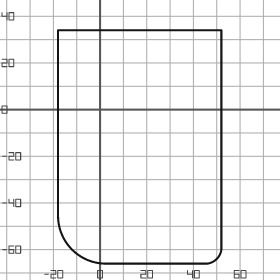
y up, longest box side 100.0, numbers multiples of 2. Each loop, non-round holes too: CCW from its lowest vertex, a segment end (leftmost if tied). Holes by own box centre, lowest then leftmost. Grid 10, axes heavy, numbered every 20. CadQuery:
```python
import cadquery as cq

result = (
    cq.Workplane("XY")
    .moveTo(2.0, -66.0)
    .lineTo(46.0, -66.0)
    .threePointArc((50.0, -64.0), (52.0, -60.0))
    .lineTo(52.0, 34.0)
    .lineTo(-18.0, 34.0)
    .lineTo(-18.0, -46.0)
    .threePointArc((-12.0, -60.0), (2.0, -66.0))
    .close()
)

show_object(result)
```